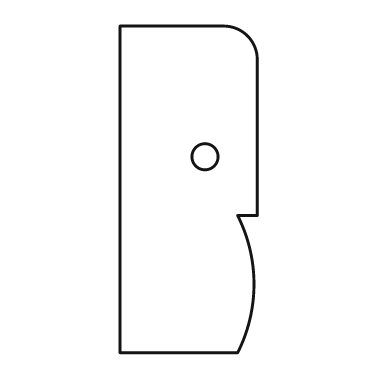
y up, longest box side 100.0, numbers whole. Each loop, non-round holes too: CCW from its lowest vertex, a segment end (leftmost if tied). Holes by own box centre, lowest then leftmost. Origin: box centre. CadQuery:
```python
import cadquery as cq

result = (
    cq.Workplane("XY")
    .moveTo(-21.0, -50.0)
    .lineTo(15.0, -50.0)
    .threePointArc((20.0, -29.0), (15.0, -8.0))
    .lineTo(21.0, -8.0)
    .lineTo(21.0, 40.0)
    .threePointArc((18.0, 47.0), (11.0, 50.0))
    .lineTo(-21.0, 50.0)
    .close()
    .moveTo(5.0, 10.0)
    .circle(4.0)
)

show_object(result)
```